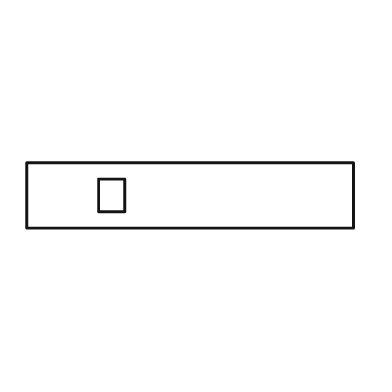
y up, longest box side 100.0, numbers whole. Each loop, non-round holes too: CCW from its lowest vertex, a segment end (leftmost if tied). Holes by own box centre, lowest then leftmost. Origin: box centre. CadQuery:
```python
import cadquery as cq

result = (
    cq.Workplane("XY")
    .moveTo(-50.0, -10.0)
    .lineTo(50.0, -10.0)
    .lineTo(50.0, 10.0)
    .lineTo(-50.0, 10.0)
    .close()
    .moveTo(-28.0, -5.0)
    .lineTo(-20.0, -5.0)
    .lineTo(-20.0, 5.0)
    .lineTo(-28.0, 5.0)
    .close()
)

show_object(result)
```